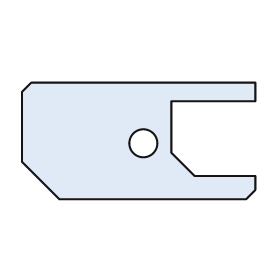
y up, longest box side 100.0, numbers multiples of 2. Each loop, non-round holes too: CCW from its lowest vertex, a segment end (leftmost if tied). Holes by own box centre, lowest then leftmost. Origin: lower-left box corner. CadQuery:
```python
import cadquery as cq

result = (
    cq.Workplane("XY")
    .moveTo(16.0, 0.0)
    .lineTo(96.0, 0.0)
    .lineTo(100.0, 4.0)
    .lineTo(100.0, 10.0)
    .lineTo(74.0, 10.0)
    .lineTo(64.0, 20.0)
    .lineTo(64.0, 42.0)
    .lineTo(100.0, 42.0)
    .lineTo(100.0, 50.0)
    .lineTo(4.0, 50.0)
    .lineTo(0.0, 46.0)
    .lineTo(0.0, 16.0)
    .close()
    .moveTo(52.0, 24.0)
    .circle(6.0)
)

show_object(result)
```